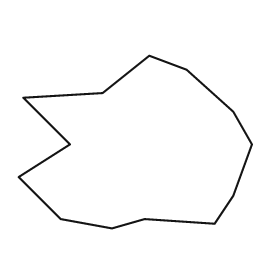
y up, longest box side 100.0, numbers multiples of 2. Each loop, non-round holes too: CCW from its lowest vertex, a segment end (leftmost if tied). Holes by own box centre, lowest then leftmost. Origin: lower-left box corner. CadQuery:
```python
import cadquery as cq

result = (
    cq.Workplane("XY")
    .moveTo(40.0, 0.0)
    .lineTo(54.0, 4.0)
    .lineTo(84.0, 2.0)
    .lineTo(92.0, 14.0)
    .lineTo(100.0, 36.0)
    .lineTo(92.0, 50.0)
    .lineTo(72.0, 68.0)
    .lineTo(56.0, 74.0)
    .lineTo(36.0, 58.0)
    .lineTo(2.0, 56.0)
    .lineTo(22.0, 36.0)
    .lineTo(0.0, 22.0)
    .lineTo(18.0, 4.0)
    .close()
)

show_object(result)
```